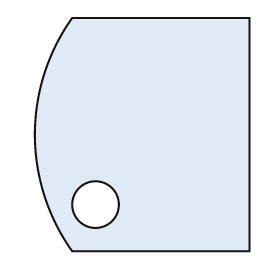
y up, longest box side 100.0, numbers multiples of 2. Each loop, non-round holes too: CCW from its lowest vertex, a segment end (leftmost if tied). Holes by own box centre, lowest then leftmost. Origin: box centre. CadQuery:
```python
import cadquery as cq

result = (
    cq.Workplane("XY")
    .moveTo(-30.0, -50.0)
    .lineTo(46.0, -50.0)
    .lineTo(46.0, 50.0)
    .lineTo(-30.0, 50.0)
    .threePointArc((-46.0, 0.0), (-30.0, -50.0))
    .close()
    .moveTo(-20.0, -30.0)
    .circle(10.0)
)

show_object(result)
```